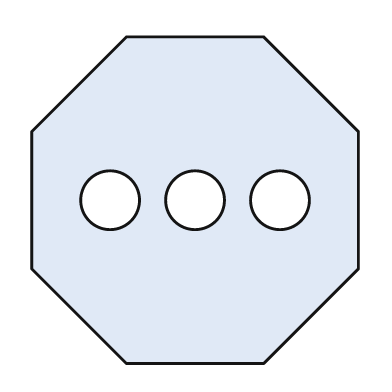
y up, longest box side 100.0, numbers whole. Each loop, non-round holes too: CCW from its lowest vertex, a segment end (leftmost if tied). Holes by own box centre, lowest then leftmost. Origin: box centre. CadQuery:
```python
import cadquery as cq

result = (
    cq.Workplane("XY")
    .moveTo(-21.0, -50.0)
    .lineTo(21.0, -50.0)
    .lineTo(50.0, -21.0)
    .lineTo(50.0, 21.0)
    .lineTo(21.0, 50.0)
    .lineTo(-21.0, 50.0)
    .lineTo(-50.0, 21.0)
    .lineTo(-50.0, -21.0)
    .close()
    .moveTo(-26.0, 0.0)
    .circle(9.0)
    .moveTo(0.0, 0.0)
    .circle(9.0)
    .moveTo(26.0, 0.0)
    .circle(9.0)
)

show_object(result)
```